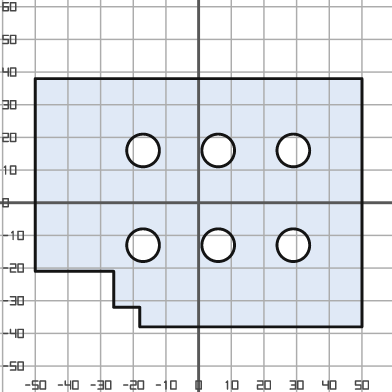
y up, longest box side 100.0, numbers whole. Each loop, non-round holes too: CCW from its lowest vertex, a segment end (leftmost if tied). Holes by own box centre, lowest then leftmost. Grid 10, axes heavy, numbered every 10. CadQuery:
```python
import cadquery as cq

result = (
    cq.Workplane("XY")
    .moveTo(-18.0, -38.0)
    .lineTo(50.0, -38.0)
    .lineTo(50.0, 38.0)
    .lineTo(-50.0, 38.0)
    .lineTo(-50.0, -21.0)
    .lineTo(-26.0, -21.0)
    .lineTo(-26.0, -32.0)
    .lineTo(-18.0, -32.0)
    .close()
    .moveTo(-17.0, -13.0)
    .circle(5.0)
    .moveTo(6.0, -13.0)
    .circle(5.0)
    .moveTo(29.0, -13.0)
    .circle(5.0)
    .moveTo(-17.0, 16.0)
    .circle(5.0)
    .moveTo(6.0, 16.0)
    .circle(5.0)
    .moveTo(29.0, 16.0)
    .circle(5.0)
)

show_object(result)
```